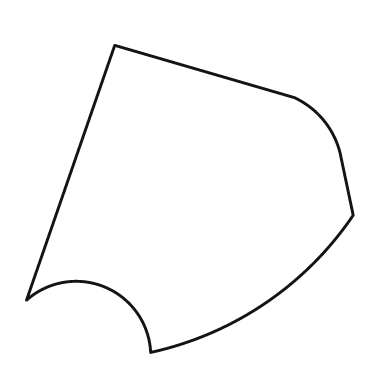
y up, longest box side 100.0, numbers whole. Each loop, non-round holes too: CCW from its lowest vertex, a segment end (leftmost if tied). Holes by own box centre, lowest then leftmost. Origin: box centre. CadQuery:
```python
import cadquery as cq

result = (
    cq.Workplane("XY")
    .moveTo(-12.0, -47.0)
    .threePointArc((23.0, -32.0), (50.0, -5.0))
    .lineTo(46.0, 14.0)
    .threePointArc((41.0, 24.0), (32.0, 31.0))
    .lineTo(-23.0, 47.0)
    .lineTo(-50.0, -31.0)
    .threePointArc((-26.0, -27.0), (-12.0, -47.0))
    .close()
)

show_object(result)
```